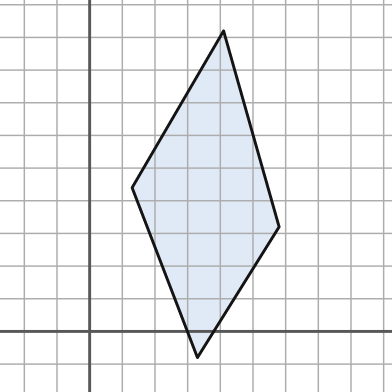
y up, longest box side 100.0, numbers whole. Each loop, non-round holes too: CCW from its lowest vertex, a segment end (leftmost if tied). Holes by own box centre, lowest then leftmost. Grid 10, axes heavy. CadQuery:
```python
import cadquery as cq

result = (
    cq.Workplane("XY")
    .moveTo(33.0, -8.0)
    .lineTo(58.0, 32.0)
    .lineTo(41.0, 92.0)
    .lineTo(13.0, 44.0)
    .close()
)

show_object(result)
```